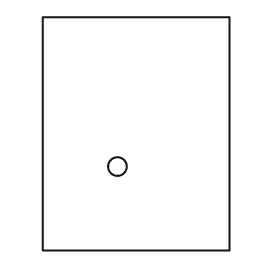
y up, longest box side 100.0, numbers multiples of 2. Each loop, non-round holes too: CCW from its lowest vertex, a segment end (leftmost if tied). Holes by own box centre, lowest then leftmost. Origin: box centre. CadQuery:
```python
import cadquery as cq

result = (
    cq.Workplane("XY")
    .moveTo(-40.0, -50.0)
    .lineTo(40.0, -50.0)
    .lineTo(40.0, 50.0)
    .lineTo(-40.0, 50.0)
    .close()
    .moveTo(-8.0, -14.0)
    .circle(4.0)
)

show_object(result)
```